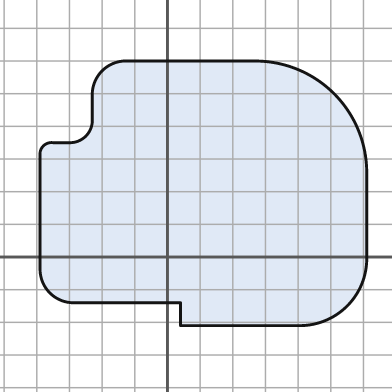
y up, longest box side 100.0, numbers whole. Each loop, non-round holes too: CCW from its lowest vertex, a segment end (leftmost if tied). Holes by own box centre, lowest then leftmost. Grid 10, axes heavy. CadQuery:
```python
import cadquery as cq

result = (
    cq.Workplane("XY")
    .moveTo(4.0, -21.0)
    .lineTo(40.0, -21.0)
    .threePointArc((55.0, -15.0), (61.0, 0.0))
    .lineTo(61.0, 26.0)
    .threePointArc((51.0, 50.0), (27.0, 60.0))
    .lineTo(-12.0, 60.0)
    .threePointArc((-20.0, 57.0), (-23.0, 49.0))
    .lineTo(-23.0, 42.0)
    .threePointArc((-25.0, 37.0), (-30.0, 35.0))
    .lineTo(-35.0, 35.0)
    .threePointArc((-38.0, 34.0), (-39.0, 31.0))
    .lineTo(-39.0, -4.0)
    .threePointArc((-36.0, -11.0), (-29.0, -14.0))
    .lineTo(4.0, -14.0)
    .close()
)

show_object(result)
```